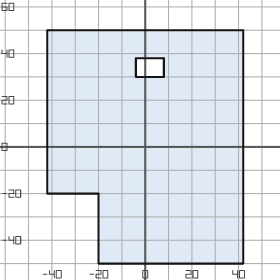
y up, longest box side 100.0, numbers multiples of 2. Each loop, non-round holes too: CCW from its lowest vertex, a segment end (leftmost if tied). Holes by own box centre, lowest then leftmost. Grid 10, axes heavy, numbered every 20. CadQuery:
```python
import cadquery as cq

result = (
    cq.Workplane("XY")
    .moveTo(-20.0, -50.0)
    .lineTo(42.0, -50.0)
    .lineTo(42.0, 50.0)
    .lineTo(-42.0, 50.0)
    .lineTo(-42.0, -20.0)
    .lineTo(-20.0, -20.0)
    .close()
    .moveTo(-4.0, 30.0)
    .lineTo(8.0, 30.0)
    .lineTo(8.0, 38.0)
    .lineTo(-4.0, 38.0)
    .close()
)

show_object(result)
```